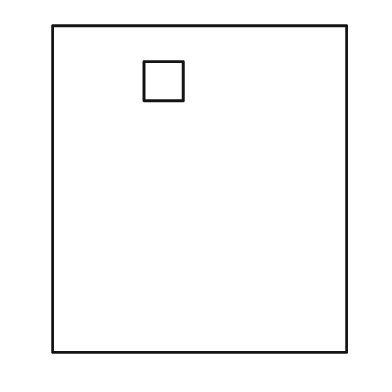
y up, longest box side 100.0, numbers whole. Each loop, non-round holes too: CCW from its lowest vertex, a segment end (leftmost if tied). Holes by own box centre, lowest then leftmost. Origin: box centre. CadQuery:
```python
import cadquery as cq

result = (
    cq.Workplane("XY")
    .moveTo(-45.0, -50.0)
    .lineTo(45.0, -50.0)
    .lineTo(45.0, 50.0)
    .lineTo(-45.0, 50.0)
    .close()
    .moveTo(-17.0, 27.0)
    .lineTo(-5.0, 27.0)
    .lineTo(-5.0, 39.0)
    .lineTo(-17.0, 39.0)
    .close()
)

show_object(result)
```